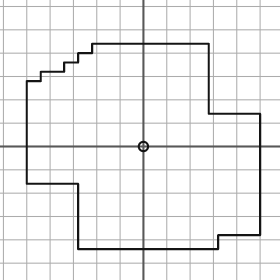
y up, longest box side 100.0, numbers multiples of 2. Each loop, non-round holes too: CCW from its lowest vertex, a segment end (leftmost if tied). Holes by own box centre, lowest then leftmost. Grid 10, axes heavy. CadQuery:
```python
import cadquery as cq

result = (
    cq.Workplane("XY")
    .moveTo(-28.0, -44.0)
    .lineTo(32.0, -44.0)
    .lineTo(32.0, -38.0)
    .lineTo(50.0, -38.0)
    .lineTo(50.0, 14.0)
    .lineTo(28.0, 14.0)
    .lineTo(28.0, 44.0)
    .lineTo(-22.0, 44.0)
    .lineTo(-22.0, 40.0)
    .lineTo(-28.0, 40.0)
    .lineTo(-28.0, 36.0)
    .lineTo(-34.0, 36.0)
    .lineTo(-34.0, 32.0)
    .lineTo(-44.0, 32.0)
    .lineTo(-44.0, 28.0)
    .lineTo(-50.0, 28.0)
    .lineTo(-50.0, -16.0)
    .lineTo(-28.0, -16.0)
    .close()
    .moveTo(0.0, 0.0)
    .circle(2.0)
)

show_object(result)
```